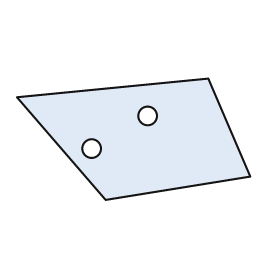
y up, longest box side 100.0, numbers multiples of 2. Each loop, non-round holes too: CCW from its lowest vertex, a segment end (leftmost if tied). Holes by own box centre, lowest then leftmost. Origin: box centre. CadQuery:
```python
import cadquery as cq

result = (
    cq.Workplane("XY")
    .moveTo(-12.0, -26.0)
    .lineTo(50.0, -16.0)
    .lineTo(32.0, 26.0)
    .lineTo(-50.0, 18.0)
    .close()
    .moveTo(-18.0, -4.0)
    .circle(4.0)
    .moveTo(6.0, 10.0)
    .circle(4.0)
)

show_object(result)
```